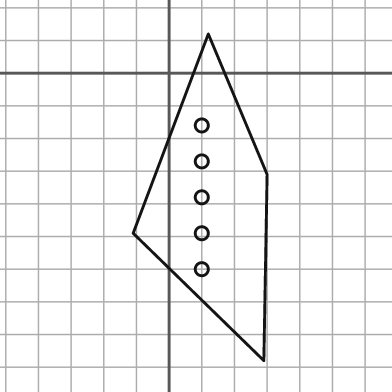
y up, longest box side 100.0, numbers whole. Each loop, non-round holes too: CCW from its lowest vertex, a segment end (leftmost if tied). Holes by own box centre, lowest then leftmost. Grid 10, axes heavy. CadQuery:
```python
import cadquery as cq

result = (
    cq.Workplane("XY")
    .moveTo(29.0, -88.0)
    .lineTo(30.0, -31.0)
    .lineTo(12.0, 12.0)
    .lineTo(-11.0, -49.0)
    .close()
    .moveTo(10.0, -60.0)
    .circle(2.0)
    .moveTo(10.0, -49.0)
    .circle(2.0)
    .moveTo(10.0, -38.0)
    .circle(2.0)
    .moveTo(10.0, -27.0)
    .circle(2.0)
    .moveTo(10.0, -16.0)
    .circle(2.0)
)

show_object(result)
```